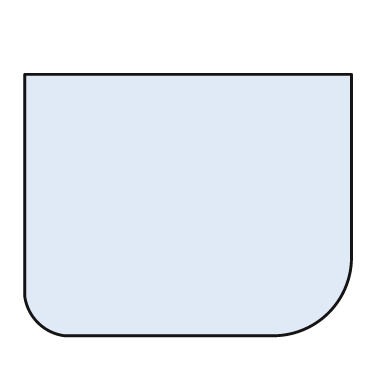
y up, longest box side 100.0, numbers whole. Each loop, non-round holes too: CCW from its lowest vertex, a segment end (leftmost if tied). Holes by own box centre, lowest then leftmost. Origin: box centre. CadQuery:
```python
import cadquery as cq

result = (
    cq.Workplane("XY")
    .moveTo(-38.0, -40.0)
    .lineTo(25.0, -40.0)
    .threePointArc((43.0, -33.0), (50.0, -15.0))
    .lineTo(50.0, 40.0)
    .lineTo(-50.0, 40.0)
    .lineTo(-50.0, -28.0)
    .threePointArc((-46.0, -36.0), (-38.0, -40.0))
    .close()
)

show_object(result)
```